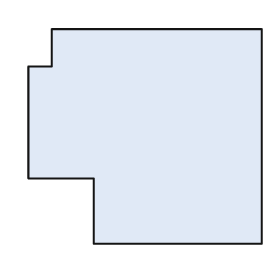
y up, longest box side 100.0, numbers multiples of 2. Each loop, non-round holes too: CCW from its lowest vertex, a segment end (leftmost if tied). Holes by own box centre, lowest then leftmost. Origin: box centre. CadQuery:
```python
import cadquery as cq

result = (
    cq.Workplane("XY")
    .moveTo(-22.0, -46.0)
    .lineTo(50.0, -46.0)
    .lineTo(50.0, 46.0)
    .lineTo(-40.0, 46.0)
    .lineTo(-40.0, 30.0)
    .lineTo(-50.0, 30.0)
    .lineTo(-50.0, -18.0)
    .lineTo(-22.0, -18.0)
    .close()
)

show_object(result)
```